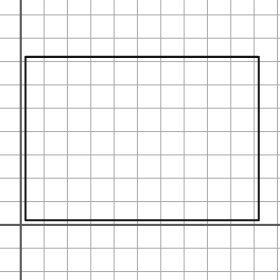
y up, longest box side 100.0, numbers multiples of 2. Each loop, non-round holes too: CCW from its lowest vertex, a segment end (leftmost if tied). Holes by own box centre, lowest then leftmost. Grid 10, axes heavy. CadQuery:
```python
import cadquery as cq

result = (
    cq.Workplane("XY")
    .moveTo(2.0, 2.0)
    .lineTo(102.0, 2.0)
    .lineTo(102.0, 72.0)
    .lineTo(2.0, 72.0)
    .close()
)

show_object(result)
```